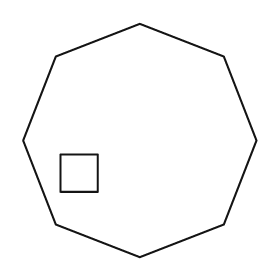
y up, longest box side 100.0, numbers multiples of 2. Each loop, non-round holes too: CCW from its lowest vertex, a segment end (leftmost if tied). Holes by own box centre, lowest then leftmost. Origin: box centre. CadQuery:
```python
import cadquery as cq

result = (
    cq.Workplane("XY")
    .moveTo(0.0, -50.0)
    .lineTo(36.0, -36.0)
    .lineTo(50.0, 0.0)
    .lineTo(36.0, 36.0)
    .lineTo(0.0, 50.0)
    .lineTo(-36.0, 36.0)
    .lineTo(-50.0, 0.0)
    .lineTo(-36.0, -36.0)
    .close()
    .moveTo(-34.0, -22.0)
    .lineTo(-18.0, -22.0)
    .lineTo(-18.0, -6.0)
    .lineTo(-34.0, -6.0)
    .close()
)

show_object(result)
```